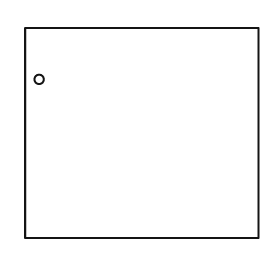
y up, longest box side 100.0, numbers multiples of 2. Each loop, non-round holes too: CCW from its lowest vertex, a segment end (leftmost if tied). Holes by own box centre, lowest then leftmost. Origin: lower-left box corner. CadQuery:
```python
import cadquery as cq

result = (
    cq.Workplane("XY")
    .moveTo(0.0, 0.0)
    .lineTo(100.0, 0.0)
    .lineTo(100.0, 90.0)
    .lineTo(0.0, 90.0)
    .close()
    .moveTo(6.0, 68.0)
    .circle(2.0)
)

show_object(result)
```